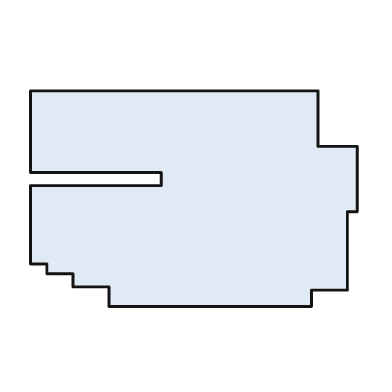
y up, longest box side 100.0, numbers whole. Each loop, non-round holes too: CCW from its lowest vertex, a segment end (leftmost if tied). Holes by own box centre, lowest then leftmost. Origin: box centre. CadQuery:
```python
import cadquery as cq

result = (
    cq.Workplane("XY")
    .moveTo(-26.0, -33.0)
    .lineTo(36.0, -33.0)
    .lineTo(36.0, -28.0)
    .lineTo(47.0, -28.0)
    .lineTo(47.0, -4.0)
    .lineTo(50.0, -4.0)
    .lineTo(50.0, 16.0)
    .lineTo(38.0, 16.0)
    .lineTo(38.0, 33.0)
    .lineTo(-50.0, 33.0)
    .lineTo(-50.0, 8.0)
    .lineTo(-10.0, 8.0)
    .lineTo(-10.0, 4.0)
    .lineTo(-50.0, 4.0)
    .lineTo(-50.0, -20.0)
    .lineTo(-45.0, -20.0)
    .lineTo(-45.0, -23.0)
    .lineTo(-37.0, -23.0)
    .lineTo(-37.0, -27.0)
    .lineTo(-26.0, -27.0)
    .close()
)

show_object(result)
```